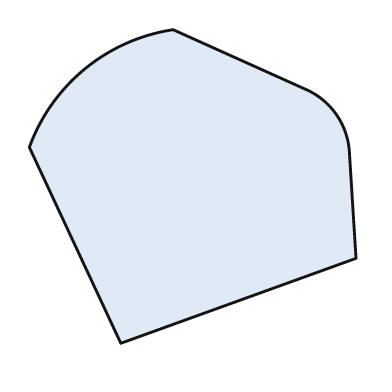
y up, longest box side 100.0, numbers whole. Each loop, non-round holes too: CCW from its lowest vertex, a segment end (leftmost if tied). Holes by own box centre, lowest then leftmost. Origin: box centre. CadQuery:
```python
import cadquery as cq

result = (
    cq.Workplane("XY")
    .moveTo(-22.0, -48.0)
    .lineTo(50.0, -22.0)
    .lineTo(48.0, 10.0)
    .threePointArc((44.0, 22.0), (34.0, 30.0))
    .lineTo(-6.0, 48.0)
    .threePointArc((-33.0, 36.0), (-50.0, 12.0))
    .close()
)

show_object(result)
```